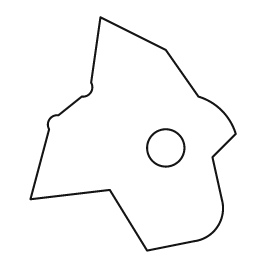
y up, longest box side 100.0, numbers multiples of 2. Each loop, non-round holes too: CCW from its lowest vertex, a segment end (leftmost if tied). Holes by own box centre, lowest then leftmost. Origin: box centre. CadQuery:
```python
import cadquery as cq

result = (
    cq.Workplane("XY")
    .moveTo(6.0, -50.0)
    .lineTo(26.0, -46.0)
    .threePointArc((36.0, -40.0), (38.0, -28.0))
    .lineTo(34.0, -10.0)
    .lineTo(44.0, 0.0)
    .threePointArc((38.0, 10.0), (28.0, 16.0))
    .lineTo(14.0, 36.0)
    .lineTo(-14.0, 50.0)
    .lineTo(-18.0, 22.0)
    .threePointArc((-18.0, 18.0), (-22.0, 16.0))
    .lineTo(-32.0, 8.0)
    .threePointArc((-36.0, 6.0), (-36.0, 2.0))
    .lineTo(-44.0, -28.0)
    .lineTo(-10.0, -24.0)
    .close()
    .moveTo(14.0, -6.0)
    .circle(8.0)
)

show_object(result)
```